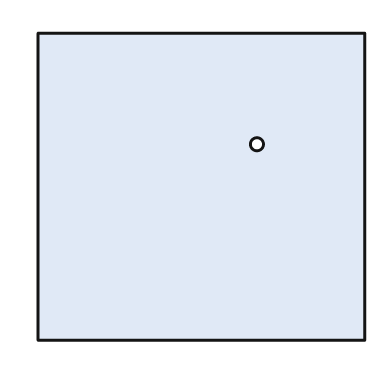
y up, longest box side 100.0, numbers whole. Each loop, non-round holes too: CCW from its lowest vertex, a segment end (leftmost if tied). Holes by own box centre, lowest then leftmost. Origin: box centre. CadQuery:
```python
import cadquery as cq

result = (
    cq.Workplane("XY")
    .moveTo(-50.0, -47.0)
    .lineTo(50.0, -47.0)
    .lineTo(50.0, 47.0)
    .lineTo(-50.0, 47.0)
    .close()
    .moveTo(17.0, 13.0)
    .circle(2.0)
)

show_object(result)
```